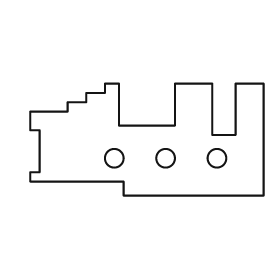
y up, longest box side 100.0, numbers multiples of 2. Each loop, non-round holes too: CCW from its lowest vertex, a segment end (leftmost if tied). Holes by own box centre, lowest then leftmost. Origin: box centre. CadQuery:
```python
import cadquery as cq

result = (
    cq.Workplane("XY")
    .moveTo(-10.0, -24.0)
    .lineTo(50.0, -24.0)
    .lineTo(50.0, 24.0)
    .lineTo(38.0, 24.0)
    .lineTo(38.0, 2.0)
    .lineTo(28.0, 2.0)
    .lineTo(28.0, 24.0)
    .lineTo(12.0, 24.0)
    .lineTo(12.0, 6.0)
    .lineTo(-12.0, 6.0)
    .lineTo(-12.0, 24.0)
    .lineTo(-18.0, 24.0)
    .lineTo(-18.0, 20.0)
    .lineTo(-26.0, 20.0)
    .lineTo(-26.0, 16.0)
    .lineTo(-34.0, 16.0)
    .lineTo(-34.0, 12.0)
    .lineTo(-50.0, 12.0)
    .lineTo(-50.0, 4.0)
    .lineTo(-46.0, 4.0)
    .lineTo(-46.0, -14.0)
    .lineTo(-50.0, -14.0)
    .lineTo(-50.0, -18.0)
    .lineTo(-10.0, -18.0)
    .close()
    .moveTo(-14.0, -8.0)
    .circle(4.0)
    .moveTo(8.0, -8.0)
    .circle(4.0)
    .moveTo(30.0, -8.0)
    .circle(4.0)
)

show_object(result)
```